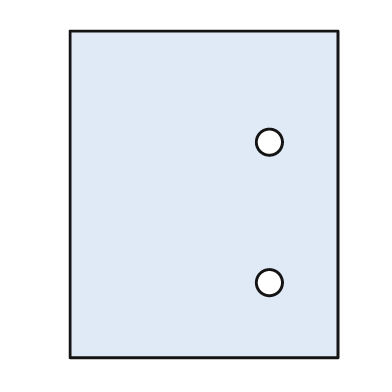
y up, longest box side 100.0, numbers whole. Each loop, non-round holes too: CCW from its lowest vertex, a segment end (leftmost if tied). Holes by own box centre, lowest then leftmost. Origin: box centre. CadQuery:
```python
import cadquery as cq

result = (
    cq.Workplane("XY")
    .moveTo(-41.0, -50.0)
    .lineTo(41.0, -50.0)
    .lineTo(41.0, 50.0)
    .lineTo(-41.0, 50.0)
    .close()
    .moveTo(20.0, -27.0)
    .circle(4.0)
    .moveTo(20.0, 16.0)
    .circle(4.0)
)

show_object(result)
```